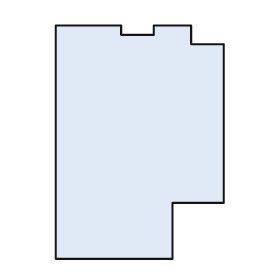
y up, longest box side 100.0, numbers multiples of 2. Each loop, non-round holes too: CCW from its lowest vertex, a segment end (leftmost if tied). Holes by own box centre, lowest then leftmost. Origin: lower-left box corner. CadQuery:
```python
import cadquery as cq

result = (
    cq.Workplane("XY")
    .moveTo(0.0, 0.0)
    .lineTo(50.0, 0.0)
    .lineTo(50.0, 24.0)
    .lineTo(72.0, 24.0)
    .lineTo(72.0, 92.0)
    .lineTo(58.0, 92.0)
    .lineTo(58.0, 100.0)
    .lineTo(42.0, 100.0)
    .lineTo(42.0, 96.0)
    .lineTo(28.0, 96.0)
    .lineTo(28.0, 100.0)
    .lineTo(0.0, 100.0)
    .close()
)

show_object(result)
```